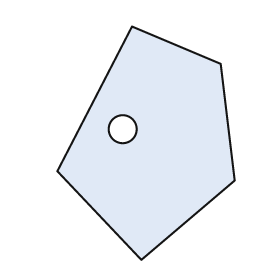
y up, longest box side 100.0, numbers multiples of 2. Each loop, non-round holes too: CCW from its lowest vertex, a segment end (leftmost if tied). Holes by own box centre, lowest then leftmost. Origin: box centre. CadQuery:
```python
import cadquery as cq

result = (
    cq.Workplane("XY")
    .moveTo(-2.0, -50.0)
    .lineTo(38.0, -16.0)
    .lineTo(32.0, 34.0)
    .lineTo(-6.0, 50.0)
    .lineTo(-38.0, -12.0)
    .close()
    .moveTo(-10.0, 6.0)
    .circle(6.0)
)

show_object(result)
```